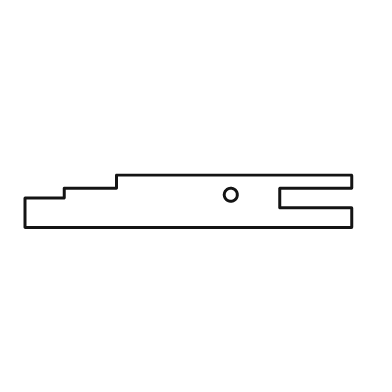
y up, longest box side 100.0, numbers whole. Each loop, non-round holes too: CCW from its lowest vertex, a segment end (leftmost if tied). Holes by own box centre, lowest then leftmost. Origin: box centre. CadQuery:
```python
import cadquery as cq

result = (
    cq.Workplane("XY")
    .moveTo(-50.0, -8.0)
    .lineTo(50.0, -8.0)
    .lineTo(50.0, -2.0)
    .lineTo(28.0, -2.0)
    .lineTo(28.0, 4.0)
    .lineTo(50.0, 4.0)
    .lineTo(50.0, 8.0)
    .lineTo(-22.0, 8.0)
    .lineTo(-22.0, 4.0)
    .lineTo(-38.0, 4.0)
    .lineTo(-38.0, 1.0)
    .lineTo(-50.0, 1.0)
    .close()
    .moveTo(13.0, 2.0)
    .circle(2.0)
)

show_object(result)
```